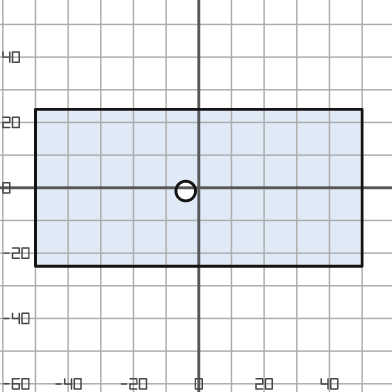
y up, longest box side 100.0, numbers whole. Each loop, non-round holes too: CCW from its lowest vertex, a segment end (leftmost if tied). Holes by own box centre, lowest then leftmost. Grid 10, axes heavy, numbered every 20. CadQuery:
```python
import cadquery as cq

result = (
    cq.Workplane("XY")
    .moveTo(-50.0, -24.0)
    .lineTo(50.0, -24.0)
    .lineTo(50.0, 24.0)
    .lineTo(-50.0, 24.0)
    .close()
    .moveTo(-4.0, -1.0)
    .circle(3.0)
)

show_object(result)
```